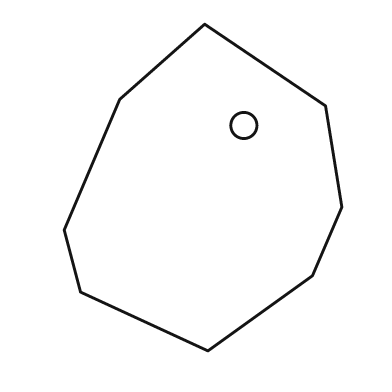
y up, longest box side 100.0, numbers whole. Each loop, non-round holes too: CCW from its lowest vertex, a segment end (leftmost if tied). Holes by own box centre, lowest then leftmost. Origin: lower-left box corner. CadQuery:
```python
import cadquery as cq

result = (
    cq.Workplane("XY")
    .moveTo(44.0, 0.0)
    .lineTo(76.0, 23.0)
    .lineTo(85.0, 44.0)
    .lineTo(80.0, 75.0)
    .lineTo(43.0, 100.0)
    .lineTo(17.0, 77.0)
    .lineTo(0.0, 37.0)
    .lineTo(5.0, 18.0)
    .close()
    .moveTo(55.0, 69.0)
    .circle(4.0)
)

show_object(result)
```